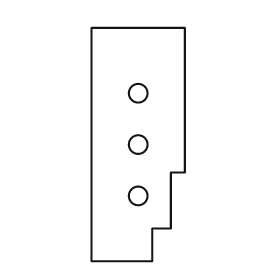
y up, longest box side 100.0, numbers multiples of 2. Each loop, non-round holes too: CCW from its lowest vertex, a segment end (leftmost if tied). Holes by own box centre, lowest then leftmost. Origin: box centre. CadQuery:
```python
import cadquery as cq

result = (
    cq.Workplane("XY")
    .moveTo(-20.0, -50.0)
    .lineTo(6.0, -50.0)
    .lineTo(6.0, -36.0)
    .lineTo(14.0, -36.0)
    .lineTo(14.0, -12.0)
    .lineTo(20.0, -12.0)
    .lineTo(20.0, 50.0)
    .lineTo(-20.0, 50.0)
    .close()
    .moveTo(0.0, -22.0)
    .circle(4.0)
    .moveTo(0.0, 0.0)
    .circle(4.0)
    .moveTo(0.0, 22.0)
    .circle(4.0)
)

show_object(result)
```